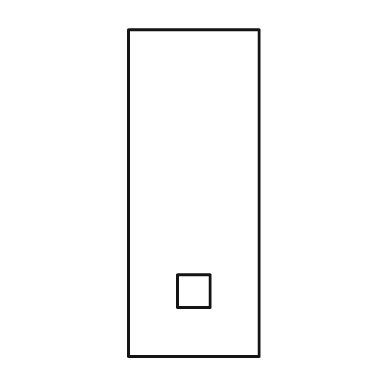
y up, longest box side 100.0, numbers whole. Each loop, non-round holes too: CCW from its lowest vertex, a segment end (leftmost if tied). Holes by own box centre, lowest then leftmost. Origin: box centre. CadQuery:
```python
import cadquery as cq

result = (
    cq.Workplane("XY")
    .moveTo(-20.0, -50.0)
    .lineTo(20.0, -50.0)
    .lineTo(20.0, 50.0)
    .lineTo(-20.0, 50.0)
    .close()
    .moveTo(-5.0, -35.0)
    .lineTo(5.0, -35.0)
    .lineTo(5.0, -25.0)
    .lineTo(-5.0, -25.0)
    .close()
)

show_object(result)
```